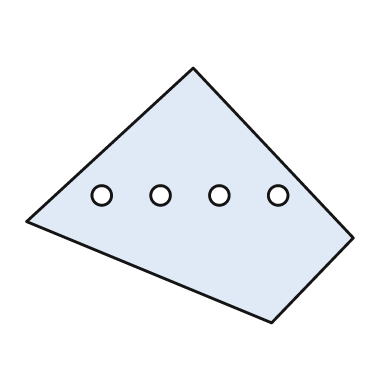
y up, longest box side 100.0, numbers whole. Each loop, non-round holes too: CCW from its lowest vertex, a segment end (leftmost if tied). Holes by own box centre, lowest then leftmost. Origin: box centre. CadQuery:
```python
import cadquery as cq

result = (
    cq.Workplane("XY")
    .moveTo(25.0, -39.0)
    .lineTo(50.0, -13.0)
    .lineTo(1.0, 39.0)
    .lineTo(-50.0, -8.0)
    .close()
    .moveTo(-27.0, 0.0)
    .circle(3.0)
    .moveTo(-9.0, 0.0)
    .circle(3.0)
    .moveTo(9.0, 0.0)
    .circle(3.0)
    .moveTo(27.0, 0.0)
    .circle(3.0)
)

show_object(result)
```